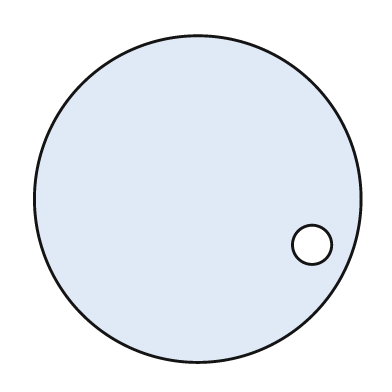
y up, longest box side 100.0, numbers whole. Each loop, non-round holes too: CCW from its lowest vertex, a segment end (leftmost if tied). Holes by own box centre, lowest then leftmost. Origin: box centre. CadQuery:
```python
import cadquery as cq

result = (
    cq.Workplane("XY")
    .moveTo(0.0, 0.0)
    .circle(50.0)
    .moveTo(35.0, -14.0)
    .circle(6.0)
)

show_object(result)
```